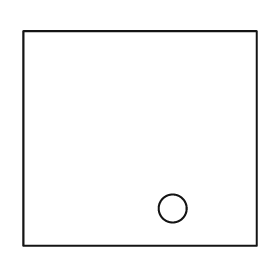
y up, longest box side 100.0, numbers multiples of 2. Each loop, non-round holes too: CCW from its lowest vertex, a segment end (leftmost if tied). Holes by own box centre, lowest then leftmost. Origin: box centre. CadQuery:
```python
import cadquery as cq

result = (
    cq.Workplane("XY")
    .moveTo(-50.0, -46.0)
    .lineTo(50.0, -46.0)
    .lineTo(50.0, 46.0)
    .lineTo(-50.0, 46.0)
    .close()
    .moveTo(14.0, -30.0)
    .circle(6.0)
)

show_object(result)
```